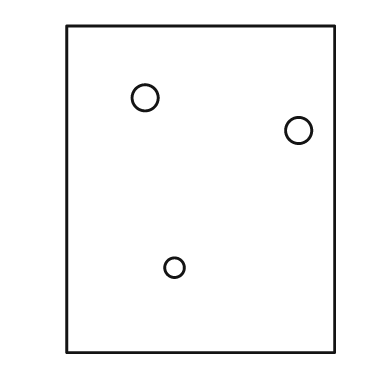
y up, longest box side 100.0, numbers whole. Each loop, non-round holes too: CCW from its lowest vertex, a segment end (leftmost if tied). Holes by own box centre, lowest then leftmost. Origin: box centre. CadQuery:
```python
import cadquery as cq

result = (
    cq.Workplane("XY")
    .moveTo(-41.0, -50.0)
    .lineTo(41.0, -50.0)
    .lineTo(41.0, 50.0)
    .lineTo(-41.0, 50.0)
    .close()
    .moveTo(-8.0, -24.0)
    .circle(3.0)
    .moveTo(30.0, 18.0)
    .circle(4.0)
    .moveTo(-17.0, 28.0)
    .circle(4.0)
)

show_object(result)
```